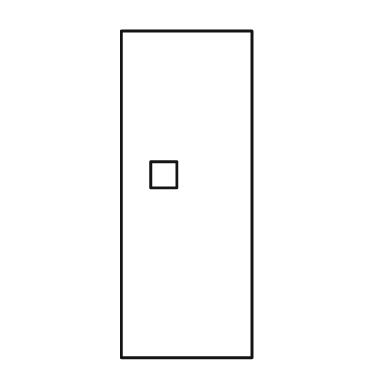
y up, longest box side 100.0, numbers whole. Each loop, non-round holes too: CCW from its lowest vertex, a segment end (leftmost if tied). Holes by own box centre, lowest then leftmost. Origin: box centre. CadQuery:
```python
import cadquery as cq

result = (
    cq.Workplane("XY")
    .moveTo(-20.0, -50.0)
    .lineTo(20.0, -50.0)
    .lineTo(20.0, 50.0)
    .lineTo(-20.0, 50.0)
    .close()
    .moveTo(-11.0, 2.0)
    .lineTo(-3.0, 2.0)
    .lineTo(-3.0, 10.0)
    .lineTo(-11.0, 10.0)
    .close()
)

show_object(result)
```